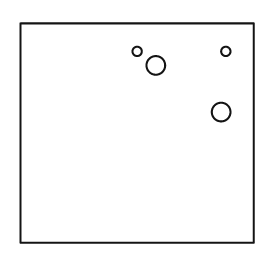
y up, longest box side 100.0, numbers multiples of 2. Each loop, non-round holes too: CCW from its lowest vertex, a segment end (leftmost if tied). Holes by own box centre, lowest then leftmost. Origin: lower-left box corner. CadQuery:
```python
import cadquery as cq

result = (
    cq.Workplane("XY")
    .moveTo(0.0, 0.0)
    .lineTo(100.0, 0.0)
    .lineTo(100.0, 94.0)
    .lineTo(0.0, 94.0)
    .close()
    .moveTo(86.0, 56.0)
    .circle(4.0)
    .moveTo(58.0, 76.0)
    .circle(4.0)
    .moveTo(50.0, 82.0)
    .circle(2.0)
    .moveTo(88.0, 82.0)
    .circle(2.0)
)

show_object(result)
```